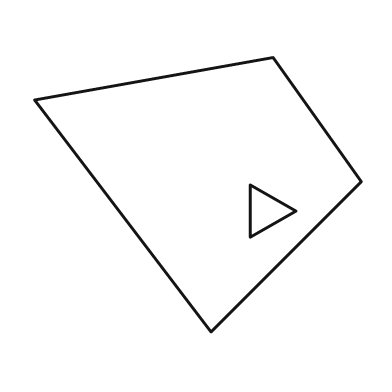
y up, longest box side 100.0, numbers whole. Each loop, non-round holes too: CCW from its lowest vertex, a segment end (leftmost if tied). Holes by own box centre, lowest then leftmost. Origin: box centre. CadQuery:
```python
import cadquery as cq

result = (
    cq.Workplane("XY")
    .moveTo(4.0, -42.0)
    .lineTo(50.0, 4.0)
    .lineTo(23.0, 42.0)
    .lineTo(-50.0, 29.0)
    .close()
    .moveTo(16.0, -13.0)
    .lineTo(30.0, -5.0)
    .lineTo(16.0, 3.0)
    .close()
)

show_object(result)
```